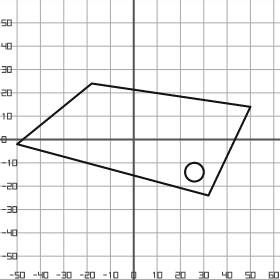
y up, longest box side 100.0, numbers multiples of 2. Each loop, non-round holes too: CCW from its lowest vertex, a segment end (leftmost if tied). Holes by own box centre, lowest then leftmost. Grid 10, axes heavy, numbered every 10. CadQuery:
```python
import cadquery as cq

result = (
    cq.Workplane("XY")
    .moveTo(32.0, -24.0)
    .lineTo(50.0, 14.0)
    .lineTo(-18.0, 24.0)
    .lineTo(-50.0, -2.0)
    .close()
    .moveTo(26.0, -14.0)
    .circle(4.0)
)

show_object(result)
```